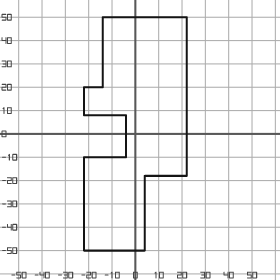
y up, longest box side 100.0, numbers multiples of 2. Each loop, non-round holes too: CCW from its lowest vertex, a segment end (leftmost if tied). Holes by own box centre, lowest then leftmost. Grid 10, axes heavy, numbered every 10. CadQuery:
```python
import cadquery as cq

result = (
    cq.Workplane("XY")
    .moveTo(-22.0, -50.0)
    .lineTo(4.0, -50.0)
    .lineTo(4.0, -18.0)
    .lineTo(22.0, -18.0)
    .lineTo(22.0, 50.0)
    .lineTo(-14.0, 50.0)
    .lineTo(-14.0, 20.0)
    .lineTo(-22.0, 20.0)
    .lineTo(-22.0, 8.0)
    .lineTo(-4.0, 8.0)
    .lineTo(-4.0, -10.0)
    .lineTo(-22.0, -10.0)
    .close()
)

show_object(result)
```